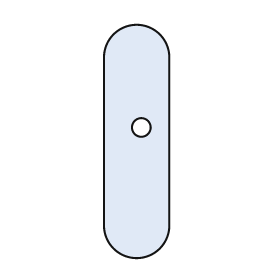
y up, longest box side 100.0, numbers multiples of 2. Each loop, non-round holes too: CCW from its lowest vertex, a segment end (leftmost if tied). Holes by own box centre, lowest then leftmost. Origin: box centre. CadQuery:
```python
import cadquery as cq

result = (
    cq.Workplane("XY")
    .moveTo(-14.0, -36.0)
    .threePointArc((0.0, -50.0), (14.0, -36.0))
    .lineTo(14.0, 36.0)
    .threePointArc((0.0, 50.0), (-14.0, 36.0))
    .close()
    .moveTo(2.0, 6.0)
    .circle(4.0)
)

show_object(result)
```